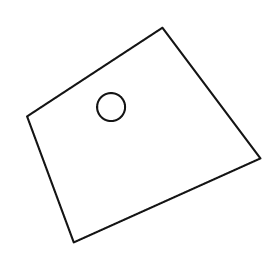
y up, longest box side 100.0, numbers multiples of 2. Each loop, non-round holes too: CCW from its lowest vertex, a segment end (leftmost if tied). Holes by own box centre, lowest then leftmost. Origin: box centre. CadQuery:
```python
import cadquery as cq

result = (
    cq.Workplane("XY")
    .moveTo(-30.0, -46.0)
    .lineTo(50.0, -10.0)
    .lineTo(8.0, 46.0)
    .lineTo(-50.0, 8.0)
    .close()
    .moveTo(-14.0, 12.0)
    .circle(6.0)
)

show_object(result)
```